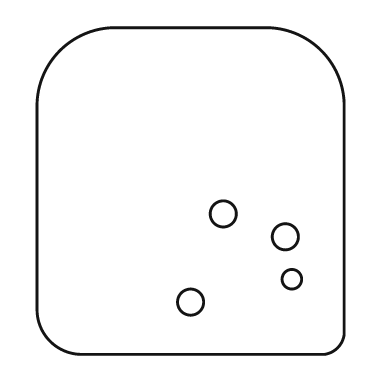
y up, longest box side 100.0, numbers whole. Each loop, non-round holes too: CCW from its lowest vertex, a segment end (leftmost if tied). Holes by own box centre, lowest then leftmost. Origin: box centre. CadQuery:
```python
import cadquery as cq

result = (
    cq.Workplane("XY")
    .moveTo(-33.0, -50.0)
    .lineTo(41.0, -50.0)
    .threePointArc((45.0, -48.0), (47.0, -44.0))
    .lineTo(47.0, 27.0)
    .threePointArc((40.0, 43.0), (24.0, 50.0))
    .lineTo(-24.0, 50.0)
    .threePointArc((-40.0, 43.0), (-47.0, 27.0))
    .lineTo(-47.0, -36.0)
    .threePointArc((-43.0, -46.0), (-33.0, -50.0))
    .close()
    .moveTo(0.0, -34.0)
    .circle(4.0)
    .moveTo(31.0, -27.0)
    .circle(3.0)
    .moveTo(29.0, -14.0)
    .circle(4.0)
    .moveTo(10.0, -7.0)
    .circle(4.0)
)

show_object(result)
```